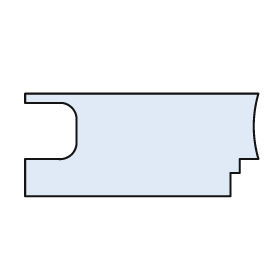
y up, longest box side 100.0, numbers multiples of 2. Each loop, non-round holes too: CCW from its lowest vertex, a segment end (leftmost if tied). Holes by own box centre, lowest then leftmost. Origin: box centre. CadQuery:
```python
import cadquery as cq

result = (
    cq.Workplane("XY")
    .moveTo(-50.0, -22.0)
    .lineTo(38.0, -22.0)
    .lineTo(38.0, -12.0)
    .lineTo(42.0, -12.0)
    .lineTo(42.0, -6.0)
    .lineTo(50.0, -6.0)
    .threePointArc((48.0, 8.0), (50.0, 22.0))
    .lineTo(-50.0, 22.0)
    .lineTo(-50.0, 18.0)
    .lineTo(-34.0, 18.0)
    .threePointArc((-30.0, 16.0), (-28.0, 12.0))
    .lineTo(-28.0, 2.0)
    .threePointArc((-30.0, -4.0), (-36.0, -6.0))
    .lineTo(-50.0, -6.0)
    .close()
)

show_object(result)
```